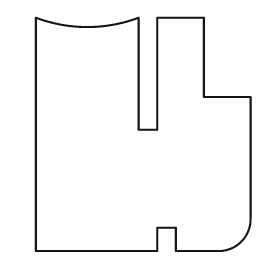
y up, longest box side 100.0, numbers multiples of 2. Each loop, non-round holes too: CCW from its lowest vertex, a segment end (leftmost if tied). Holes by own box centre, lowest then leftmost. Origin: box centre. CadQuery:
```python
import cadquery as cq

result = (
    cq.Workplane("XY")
    .moveTo(-46.0, -50.0)
    .lineTo(6.0, -50.0)
    .lineTo(6.0, -40.0)
    .lineTo(14.0, -40.0)
    .lineTo(14.0, -50.0)
    .lineTo(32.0, -50.0)
    .threePointArc((42.0, -46.0), (46.0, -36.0))
    .lineTo(46.0, 16.0)
    .lineTo(26.0, 16.0)
    .lineTo(26.0, 50.0)
    .lineTo(6.0, 50.0)
    .lineTo(6.0, 2.0)
    .lineTo(-2.0, 2.0)
    .lineTo(-2.0, 50.0)
    .threePointArc((-24.0, 46.0), (-46.0, 50.0))
    .close()
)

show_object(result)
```